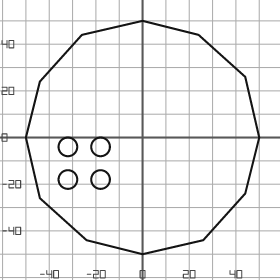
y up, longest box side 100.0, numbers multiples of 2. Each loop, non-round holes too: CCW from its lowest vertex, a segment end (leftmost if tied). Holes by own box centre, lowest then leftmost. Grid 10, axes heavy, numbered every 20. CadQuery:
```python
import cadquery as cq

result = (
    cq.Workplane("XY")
    .moveTo(0.0, -50.0)
    .lineTo(26.0, -44.0)
    .lineTo(44.0, -24.0)
    .lineTo(50.0, 0.0)
    .lineTo(44.0, 26.0)
    .lineTo(24.0, 44.0)
    .lineTo(0.0, 50.0)
    .lineTo(-26.0, 44.0)
    .lineTo(-44.0, 24.0)
    .lineTo(-50.0, 0.0)
    .lineTo(-44.0, -26.0)
    .lineTo(-24.0, -44.0)
    .close()
    .moveTo(-32.0, -18.0)
    .circle(4.0)
    .moveTo(-18.0, -18.0)
    .circle(4.0)
    .moveTo(-32.0, -4.0)
    .circle(4.0)
    .moveTo(-18.0, -4.0)
    .circle(4.0)
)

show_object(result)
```